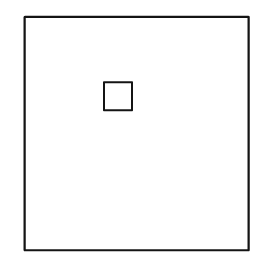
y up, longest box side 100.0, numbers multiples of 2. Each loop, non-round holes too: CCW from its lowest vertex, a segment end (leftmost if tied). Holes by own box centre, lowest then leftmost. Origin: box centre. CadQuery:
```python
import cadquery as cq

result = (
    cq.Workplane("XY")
    .moveTo(-48.0, -50.0)
    .lineTo(48.0, -50.0)
    .lineTo(48.0, 50.0)
    .lineTo(-48.0, 50.0)
    .close()
    .moveTo(-14.0, 10.0)
    .lineTo(-2.0, 10.0)
    .lineTo(-2.0, 22.0)
    .lineTo(-14.0, 22.0)
    .close()
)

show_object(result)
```